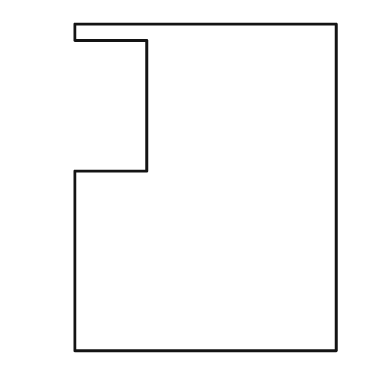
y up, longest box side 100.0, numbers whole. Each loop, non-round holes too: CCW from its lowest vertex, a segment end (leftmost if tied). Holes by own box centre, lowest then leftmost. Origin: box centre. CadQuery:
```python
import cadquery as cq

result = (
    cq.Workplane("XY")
    .moveTo(-40.0, -50.0)
    .lineTo(40.0, -50.0)
    .lineTo(40.0, 50.0)
    .lineTo(-40.0, 50.0)
    .lineTo(-40.0, 45.0)
    .lineTo(-18.0, 45.0)
    .lineTo(-18.0, 5.0)
    .lineTo(-40.0, 5.0)
    .close()
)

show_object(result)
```